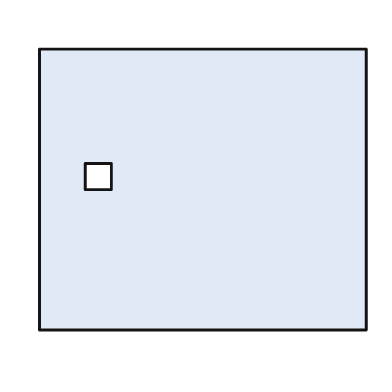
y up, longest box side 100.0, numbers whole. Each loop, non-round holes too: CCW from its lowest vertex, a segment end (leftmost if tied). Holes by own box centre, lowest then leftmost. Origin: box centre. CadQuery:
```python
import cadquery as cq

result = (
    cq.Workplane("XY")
    .moveTo(-50.0, -43.0)
    .lineTo(50.0, -43.0)
    .lineTo(50.0, 43.0)
    .lineTo(-50.0, 43.0)
    .close()
    .moveTo(-36.0, 0.0)
    .lineTo(-28.0, 0.0)
    .lineTo(-28.0, 8.0)
    .lineTo(-36.0, 8.0)
    .close()
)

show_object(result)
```